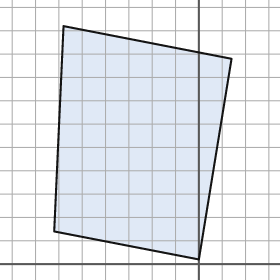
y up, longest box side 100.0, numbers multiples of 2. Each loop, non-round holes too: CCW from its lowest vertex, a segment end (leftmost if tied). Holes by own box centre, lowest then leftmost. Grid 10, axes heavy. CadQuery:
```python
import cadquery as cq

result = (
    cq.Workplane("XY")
    .moveTo(0.0, 2.0)
    .lineTo(14.0, 88.0)
    .lineTo(-58.0, 102.0)
    .lineTo(-62.0, 14.0)
    .close()
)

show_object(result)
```